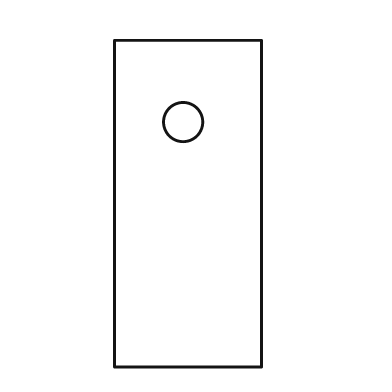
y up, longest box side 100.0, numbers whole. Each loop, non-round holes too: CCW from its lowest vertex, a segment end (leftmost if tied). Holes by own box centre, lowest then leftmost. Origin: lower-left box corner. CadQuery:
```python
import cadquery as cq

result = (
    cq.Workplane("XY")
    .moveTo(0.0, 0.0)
    .lineTo(45.0, 0.0)
    .lineTo(45.0, 100.0)
    .lineTo(0.0, 100.0)
    .close()
    .moveTo(21.0, 75.0)
    .circle(6.0)
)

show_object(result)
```